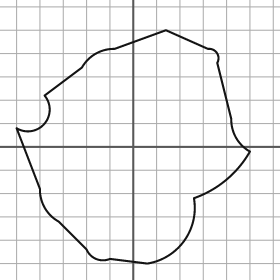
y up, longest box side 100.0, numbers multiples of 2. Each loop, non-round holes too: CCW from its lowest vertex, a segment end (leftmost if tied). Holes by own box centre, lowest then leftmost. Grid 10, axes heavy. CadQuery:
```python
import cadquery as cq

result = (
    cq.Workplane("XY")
    .moveTo(6.0, -50.0)
    .threePointArc((22.0, -40.0), (26.0, -22.0))
    .threePointArc((40.0, -14.0), (50.0, -2.0))
    .threePointArc((44.0, 4.0), (42.0, 12.0))
    .lineTo(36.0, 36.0)
    .threePointArc((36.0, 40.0), (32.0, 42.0))
    .lineTo(14.0, 50.0)
    .lineTo(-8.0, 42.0)
    .threePointArc((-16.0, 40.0), (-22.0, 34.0))
    .lineTo(-38.0, 22.0)
    .threePointArc((-38.0, 10.0), (-50.0, 8.0))
    .lineTo(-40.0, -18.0)
    .threePointArc((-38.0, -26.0), (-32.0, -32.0))
    .lineTo(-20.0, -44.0)
    .threePointArc((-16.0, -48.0), (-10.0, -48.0))
    .close()
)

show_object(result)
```